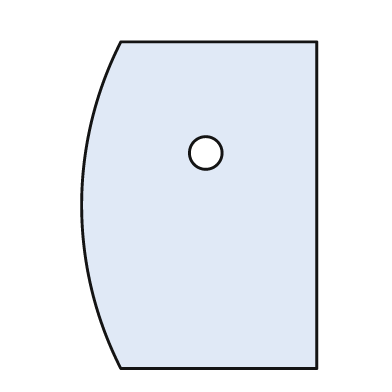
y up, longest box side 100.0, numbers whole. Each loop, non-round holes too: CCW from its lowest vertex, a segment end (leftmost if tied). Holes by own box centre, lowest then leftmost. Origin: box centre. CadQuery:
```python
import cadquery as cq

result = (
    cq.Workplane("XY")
    .moveTo(-24.0, -50.0)
    .lineTo(36.0, -50.0)
    .lineTo(36.0, 50.0)
    .lineTo(-24.0, 50.0)
    .threePointArc((-36.0, 0.0), (-24.0, -50.0))
    .close()
    .moveTo(2.0, 16.0)
    .circle(5.0)
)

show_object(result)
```